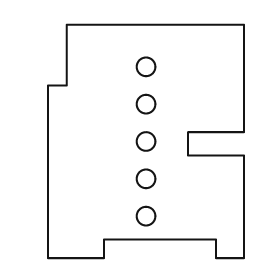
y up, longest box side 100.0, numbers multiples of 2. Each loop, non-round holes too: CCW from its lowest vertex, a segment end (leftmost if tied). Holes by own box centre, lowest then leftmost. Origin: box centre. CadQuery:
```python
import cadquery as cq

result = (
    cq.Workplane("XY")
    .moveTo(-42.0, -50.0)
    .lineTo(-18.0, -50.0)
    .lineTo(-18.0, -42.0)
    .lineTo(30.0, -42.0)
    .lineTo(30.0, -50.0)
    .lineTo(42.0, -50.0)
    .lineTo(42.0, -6.0)
    .lineTo(18.0, -6.0)
    .lineTo(18.0, 4.0)
    .lineTo(42.0, 4.0)
    .lineTo(42.0, 50.0)
    .lineTo(-34.0, 50.0)
    .lineTo(-34.0, 24.0)
    .lineTo(-42.0, 24.0)
    .close()
    .moveTo(0.0, -32.0)
    .circle(4.0)
    .moveTo(0.0, -16.0)
    .circle(4.0)
    .moveTo(0.0, 0.0)
    .circle(4.0)
    .moveTo(0.0, 16.0)
    .circle(4.0)
    .moveTo(0.0, 32.0)
    .circle(4.0)
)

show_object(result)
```